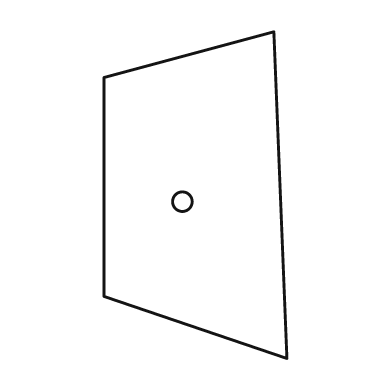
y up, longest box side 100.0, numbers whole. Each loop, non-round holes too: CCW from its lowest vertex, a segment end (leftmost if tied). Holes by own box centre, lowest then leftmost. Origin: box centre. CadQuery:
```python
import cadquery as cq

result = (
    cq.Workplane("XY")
    .moveTo(28.0, -50.0)
    .lineTo(24.0, 50.0)
    .lineTo(-28.0, 36.0)
    .lineTo(-28.0, -31.0)
    .close()
    .moveTo(-4.0, -2.0)
    .circle(3.0)
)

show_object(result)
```